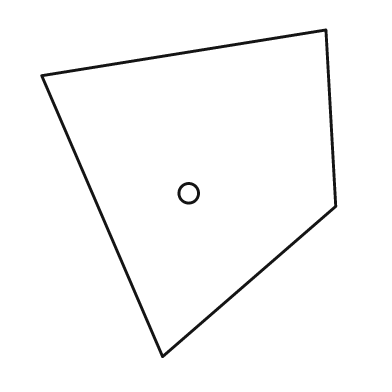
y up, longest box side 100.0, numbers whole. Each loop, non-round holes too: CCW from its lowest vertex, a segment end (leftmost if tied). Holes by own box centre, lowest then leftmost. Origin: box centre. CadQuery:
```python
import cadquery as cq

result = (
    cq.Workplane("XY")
    .moveTo(-8.0, -50.0)
    .lineTo(45.0, -4.0)
    .lineTo(42.0, 50.0)
    .lineTo(-45.0, 36.0)
    .close()
    .moveTo(0.0, 0.0)
    .circle(3.0)
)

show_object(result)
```